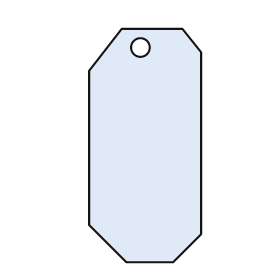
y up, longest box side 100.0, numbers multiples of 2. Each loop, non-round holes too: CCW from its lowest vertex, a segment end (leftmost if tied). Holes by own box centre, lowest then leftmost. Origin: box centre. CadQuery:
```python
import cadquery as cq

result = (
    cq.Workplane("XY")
    .moveTo(-8.0, -50.0)
    .lineTo(12.0, -50.0)
    .lineTo(24.0, -38.0)
    .lineTo(24.0, 40.0)
    .lineTo(16.0, 50.0)
    .lineTo(-10.0, 50.0)
    .lineTo(-24.0, 32.0)
    .lineTo(-24.0, -34.0)
    .close()
    .moveTo(-2.0, 42.0)
    .circle(4.0)
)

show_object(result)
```